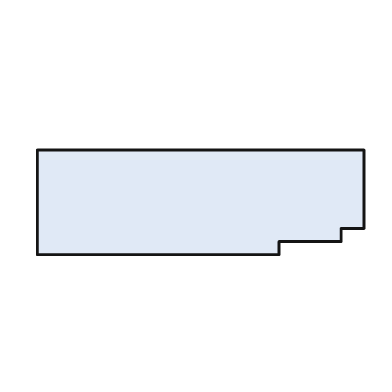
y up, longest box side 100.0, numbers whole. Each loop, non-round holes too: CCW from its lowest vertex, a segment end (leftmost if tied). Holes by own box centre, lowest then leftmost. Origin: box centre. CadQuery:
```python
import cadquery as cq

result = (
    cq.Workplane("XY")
    .moveTo(-50.0, -16.0)
    .lineTo(24.0, -16.0)
    .lineTo(24.0, -12.0)
    .lineTo(43.0, -12.0)
    .lineTo(43.0, -8.0)
    .lineTo(50.0, -8.0)
    .lineTo(50.0, 16.0)
    .lineTo(-50.0, 16.0)
    .close()
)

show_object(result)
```